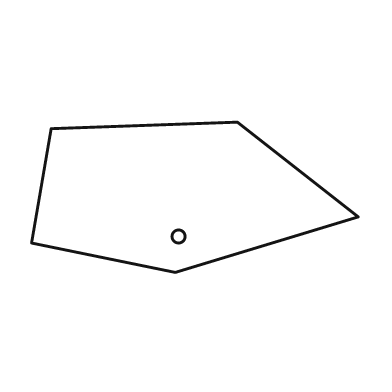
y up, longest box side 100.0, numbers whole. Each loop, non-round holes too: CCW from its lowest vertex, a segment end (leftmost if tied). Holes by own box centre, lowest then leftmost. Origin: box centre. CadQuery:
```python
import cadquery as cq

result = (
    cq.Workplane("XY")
    .moveTo(-6.0, -23.0)
    .lineTo(50.0, -6.0)
    .lineTo(13.0, 23.0)
    .lineTo(-44.0, 21.0)
    .lineTo(-50.0, -14.0)
    .close()
    .moveTo(-5.0, -12.0)
    .circle(2.0)
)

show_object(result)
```